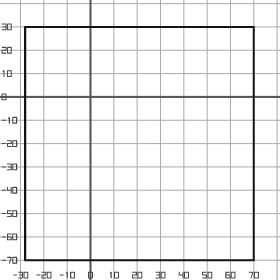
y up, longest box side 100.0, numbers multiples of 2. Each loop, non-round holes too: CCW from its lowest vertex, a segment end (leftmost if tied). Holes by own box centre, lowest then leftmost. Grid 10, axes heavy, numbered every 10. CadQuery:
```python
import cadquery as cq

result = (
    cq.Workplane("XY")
    .moveTo(-28.0, -70.0)
    .lineTo(70.0, -70.0)
    .lineTo(70.0, 30.0)
    .lineTo(-28.0, 30.0)
    .close()
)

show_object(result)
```